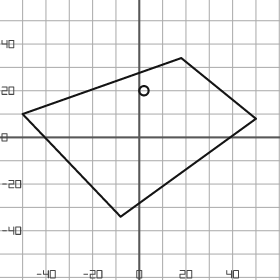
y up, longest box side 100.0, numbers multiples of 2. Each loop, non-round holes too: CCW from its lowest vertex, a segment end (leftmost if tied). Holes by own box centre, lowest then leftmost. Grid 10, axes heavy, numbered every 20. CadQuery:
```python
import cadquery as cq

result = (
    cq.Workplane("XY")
    .moveTo(-8.0, -34.0)
    .lineTo(50.0, 8.0)
    .lineTo(18.0, 34.0)
    .lineTo(-50.0, 10.0)
    .close()
    .moveTo(2.0, 20.0)
    .circle(2.0)
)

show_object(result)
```